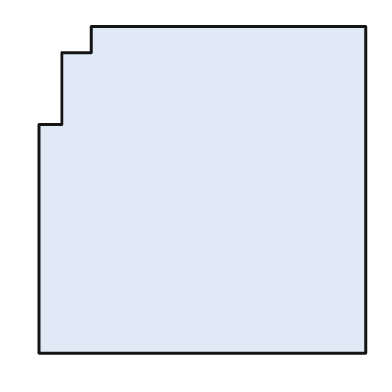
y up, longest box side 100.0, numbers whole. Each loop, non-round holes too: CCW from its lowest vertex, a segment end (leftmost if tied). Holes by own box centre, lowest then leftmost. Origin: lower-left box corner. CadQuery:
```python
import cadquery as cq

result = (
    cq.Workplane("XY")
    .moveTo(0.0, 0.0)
    .lineTo(100.0, 0.0)
    .lineTo(100.0, 100.0)
    .lineTo(16.0, 100.0)
    .lineTo(16.0, 92.0)
    .lineTo(7.0, 92.0)
    .lineTo(7.0, 70.0)
    .lineTo(0.0, 70.0)
    .close()
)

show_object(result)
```